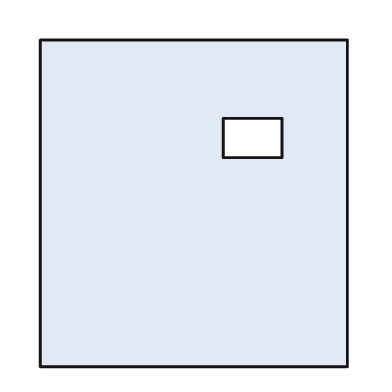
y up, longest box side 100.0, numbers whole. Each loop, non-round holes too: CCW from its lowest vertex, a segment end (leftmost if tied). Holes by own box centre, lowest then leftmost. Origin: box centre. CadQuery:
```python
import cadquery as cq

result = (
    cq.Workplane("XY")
    .moveTo(-47.0, -50.0)
    .lineTo(47.0, -50.0)
    .lineTo(47.0, 50.0)
    .lineTo(-47.0, 50.0)
    .close()
    .moveTo(9.0, 14.0)
    .lineTo(27.0, 14.0)
    .lineTo(27.0, 26.0)
    .lineTo(9.0, 26.0)
    .close()
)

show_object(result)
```